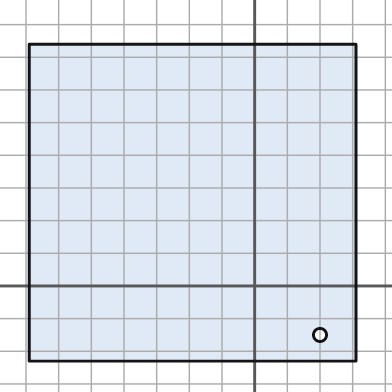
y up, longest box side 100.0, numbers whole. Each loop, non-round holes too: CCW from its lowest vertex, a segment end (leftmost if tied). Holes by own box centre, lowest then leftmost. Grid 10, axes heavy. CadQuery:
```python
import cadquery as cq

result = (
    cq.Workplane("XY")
    .moveTo(-69.0, -23.0)
    .lineTo(31.0, -23.0)
    .lineTo(31.0, 74.0)
    .lineTo(-69.0, 74.0)
    .close()
    .moveTo(20.0, -15.0)
    .circle(2.0)
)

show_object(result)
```